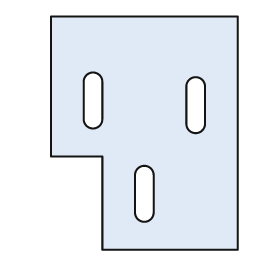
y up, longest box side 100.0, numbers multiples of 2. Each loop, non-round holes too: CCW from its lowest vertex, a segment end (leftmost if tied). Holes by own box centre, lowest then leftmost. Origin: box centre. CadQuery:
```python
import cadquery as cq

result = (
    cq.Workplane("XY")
    .moveTo(-18.0, -50.0)
    .lineTo(40.0, -50.0)
    .lineTo(40.0, 50.0)
    .lineTo(-40.0, 50.0)
    .lineTo(-40.0, -10.0)
    .lineTo(-18.0, -10.0)
    .close()
    .moveTo(-4.0, -34.0)
    .threePointArc((0.0, -38.0), (4.0, -34.0))
    .lineTo(4.0, -18.0)
    .threePointArc((0.0, -14.0), (-4.0, -18.0))
    .close()
    .moveTo(18.0, 4.0)
    .threePointArc((22.0, 0.0), (26.0, 4.0))
    .lineTo(26.0, 20.0)
    .threePointArc((22.0, 24.0), (18.0, 20.0))
    .close()
    .moveTo(-26.0, 6.0)
    .threePointArc((-22.0, 2.0), (-18.0, 6.0))
    .lineTo(-18.0, 22.0)
    .threePointArc((-22.0, 26.0), (-26.0, 22.0))
    .close()
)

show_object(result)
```